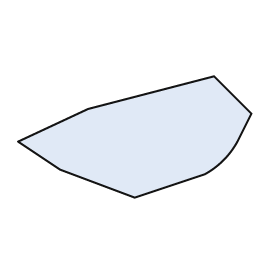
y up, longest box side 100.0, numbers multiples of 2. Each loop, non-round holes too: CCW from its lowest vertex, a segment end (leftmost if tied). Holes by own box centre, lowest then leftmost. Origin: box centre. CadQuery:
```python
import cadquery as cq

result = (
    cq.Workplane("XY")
    .moveTo(0.0, -26.0)
    .lineTo(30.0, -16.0)
    .threePointArc((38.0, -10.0), (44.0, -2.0))
    .lineTo(50.0, 10.0)
    .lineTo(34.0, 26.0)
    .lineTo(-20.0, 12.0)
    .lineTo(-50.0, -2.0)
    .lineTo(-32.0, -14.0)
    .close()
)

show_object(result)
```